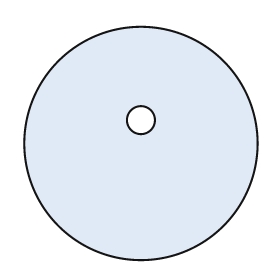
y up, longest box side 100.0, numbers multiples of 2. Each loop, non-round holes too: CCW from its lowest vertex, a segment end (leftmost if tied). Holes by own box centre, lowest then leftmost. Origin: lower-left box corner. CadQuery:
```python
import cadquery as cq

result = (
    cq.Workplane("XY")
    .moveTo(50.0, 50.0)
    .circle(50.0)
    .moveTo(50.0, 60.0)
    .circle(6.0)
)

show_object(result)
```